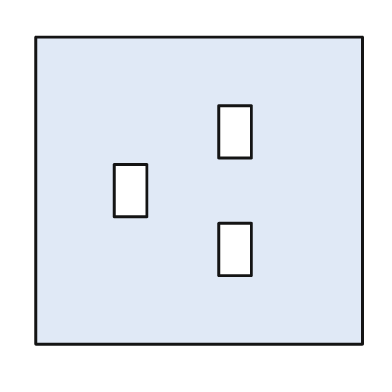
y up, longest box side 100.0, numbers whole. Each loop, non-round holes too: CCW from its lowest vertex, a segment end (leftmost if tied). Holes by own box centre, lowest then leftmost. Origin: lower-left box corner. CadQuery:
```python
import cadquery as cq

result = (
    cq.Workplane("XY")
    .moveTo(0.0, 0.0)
    .lineTo(100.0, 0.0)
    .lineTo(100.0, 94.0)
    .lineTo(0.0, 94.0)
    .close()
    .moveTo(56.0, 21.0)
    .lineTo(66.0, 21.0)
    .lineTo(66.0, 37.0)
    .lineTo(56.0, 37.0)
    .close()
    .moveTo(24.0, 39.0)
    .lineTo(34.0, 39.0)
    .lineTo(34.0, 55.0)
    .lineTo(24.0, 55.0)
    .close()
    .moveTo(56.0, 57.0)
    .lineTo(66.0, 57.0)
    .lineTo(66.0, 73.0)
    .lineTo(56.0, 73.0)
    .close()
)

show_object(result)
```